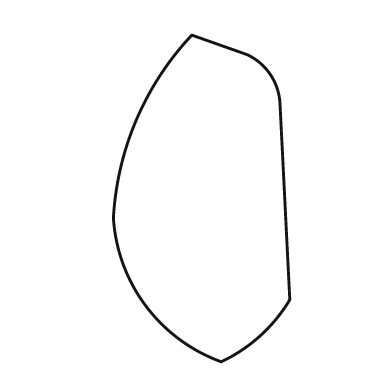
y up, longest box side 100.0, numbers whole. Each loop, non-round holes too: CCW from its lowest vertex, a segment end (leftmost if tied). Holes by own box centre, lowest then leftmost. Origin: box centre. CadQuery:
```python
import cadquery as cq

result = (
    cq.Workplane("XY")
    .moveTo(6.0, -50.0)
    .threePointArc((18.0, -42.0), (27.0, -31.0))
    .lineTo(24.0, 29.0)
    .threePointArc((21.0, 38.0), (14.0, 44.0))
    .lineTo(-3.0, 50.0)
    .threePointArc((-20.0, 24.0), (-27.0, -6.0))
    .threePointArc((-17.0, -33.0), (6.0, -50.0))
    .close()
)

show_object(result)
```